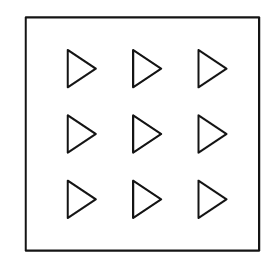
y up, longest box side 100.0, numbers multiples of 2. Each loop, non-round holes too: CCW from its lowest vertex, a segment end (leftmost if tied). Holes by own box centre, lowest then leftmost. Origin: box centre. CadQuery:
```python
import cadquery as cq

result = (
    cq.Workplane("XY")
    .moveTo(-50.0, -50.0)
    .lineTo(50.0, -50.0)
    .lineTo(50.0, 50.0)
    .lineTo(-50.0, 50.0)
    .close()
    .moveTo(-32.0, -36.0)
    .lineTo(-20.0, -28.0)
    .lineTo(-32.0, -20.0)
    .close()
    .moveTo(-4.0, -36.0)
    .lineTo(8.0, -28.0)
    .lineTo(-4.0, -20.0)
    .close()
    .moveTo(24.0, -36.0)
    .lineTo(36.0, -28.0)
    .lineTo(24.0, -20.0)
    .close()
    .moveTo(-32.0, -8.0)
    .lineTo(-20.0, 0.0)
    .lineTo(-32.0, 8.0)
    .close()
    .moveTo(-4.0, -8.0)
    .lineTo(8.0, 0.0)
    .lineTo(-4.0, 8.0)
    .close()
    .moveTo(24.0, -8.0)
    .lineTo(36.0, 0.0)
    .lineTo(24.0, 8.0)
    .close()
    .moveTo(-32.0, 20.0)
    .lineTo(-20.0, 28.0)
    .lineTo(-32.0, 36.0)
    .close()
    .moveTo(-4.0, 20.0)
    .lineTo(8.0, 28.0)
    .lineTo(-4.0, 36.0)
    .close()
    .moveTo(24.0, 20.0)
    .lineTo(36.0, 28.0)
    .lineTo(24.0, 36.0)
    .close()
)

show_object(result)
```